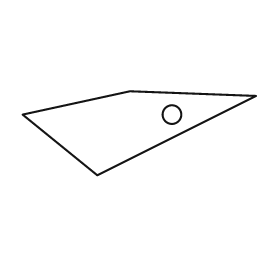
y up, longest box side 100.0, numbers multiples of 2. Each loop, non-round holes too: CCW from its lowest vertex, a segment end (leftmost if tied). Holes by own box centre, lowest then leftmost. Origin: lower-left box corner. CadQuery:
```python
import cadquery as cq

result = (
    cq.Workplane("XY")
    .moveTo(32.0, 0.0)
    .lineTo(100.0, 34.0)
    .lineTo(46.0, 36.0)
    .lineTo(0.0, 26.0)
    .close()
    .moveTo(64.0, 26.0)
    .circle(4.0)
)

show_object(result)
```